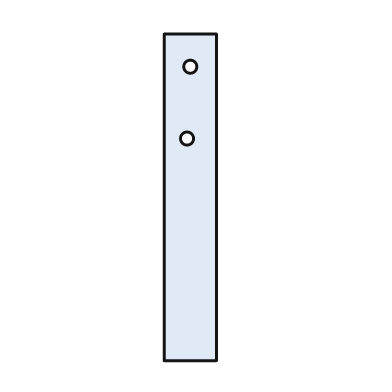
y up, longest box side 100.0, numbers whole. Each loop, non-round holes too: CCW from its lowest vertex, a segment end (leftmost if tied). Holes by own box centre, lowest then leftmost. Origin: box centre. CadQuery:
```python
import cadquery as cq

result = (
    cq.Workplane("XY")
    .moveTo(-8.0, -50.0)
    .lineTo(8.0, -50.0)
    .lineTo(8.0, 50.0)
    .lineTo(-8.0, 50.0)
    .close()
    .moveTo(-1.0, 18.0)
    .circle(2.0)
    .moveTo(0.0, 40.0)
    .circle(2.0)
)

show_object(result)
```